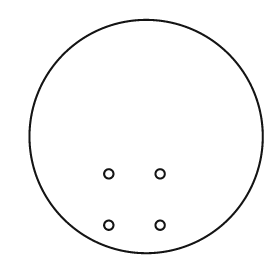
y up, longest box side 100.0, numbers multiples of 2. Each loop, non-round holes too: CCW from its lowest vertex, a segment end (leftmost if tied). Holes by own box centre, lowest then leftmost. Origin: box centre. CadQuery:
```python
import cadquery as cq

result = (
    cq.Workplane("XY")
    .moveTo(0.0, 0.0)
    .circle(50.0)
    .moveTo(-16.0, -38.0)
    .circle(2.0)
    .moveTo(6.0, -38.0)
    .circle(2.0)
    .moveTo(-16.0, -16.0)
    .circle(2.0)
    .moveTo(6.0, -16.0)
    .circle(2.0)
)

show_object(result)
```